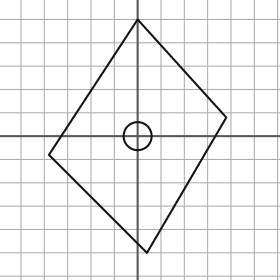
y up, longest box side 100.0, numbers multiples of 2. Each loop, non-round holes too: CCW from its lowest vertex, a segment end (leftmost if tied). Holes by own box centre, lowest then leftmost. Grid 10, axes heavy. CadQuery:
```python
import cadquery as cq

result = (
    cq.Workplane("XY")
    .moveTo(4.0, -50.0)
    .lineTo(38.0, 8.0)
    .lineTo(0.0, 50.0)
    .lineTo(-38.0, -8.0)
    .close()
    .moveTo(0.0, 0.0)
    .circle(6.0)
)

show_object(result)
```